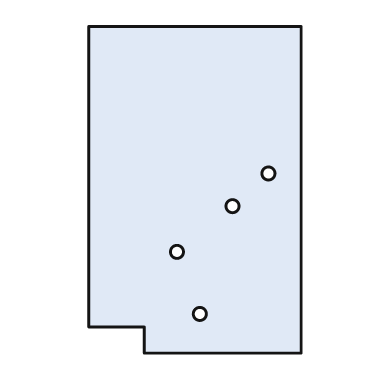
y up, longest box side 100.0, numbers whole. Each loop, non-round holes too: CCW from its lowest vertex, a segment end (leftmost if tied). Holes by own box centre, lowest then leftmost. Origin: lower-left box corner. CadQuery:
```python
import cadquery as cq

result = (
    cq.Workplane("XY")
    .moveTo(17.0, 0.0)
    .lineTo(65.0, 0.0)
    .lineTo(65.0, 100.0)
    .lineTo(0.0, 100.0)
    .lineTo(0.0, 8.0)
    .lineTo(17.0, 8.0)
    .close()
    .moveTo(34.0, 12.0)
    .circle(2.0)
    .moveTo(27.0, 31.0)
    .circle(2.0)
    .moveTo(44.0, 45.0)
    .circle(2.0)
    .moveTo(55.0, 55.0)
    .circle(2.0)
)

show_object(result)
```